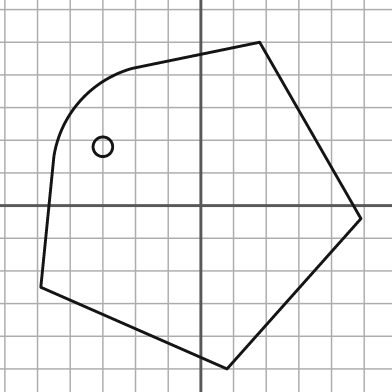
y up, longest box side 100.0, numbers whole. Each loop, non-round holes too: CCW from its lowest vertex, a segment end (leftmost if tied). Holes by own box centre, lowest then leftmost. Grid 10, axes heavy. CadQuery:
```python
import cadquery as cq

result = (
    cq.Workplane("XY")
    .moveTo(8.0, -50.0)
    .lineTo(49.0, -4.0)
    .lineTo(18.0, 50.0)
    .lineTo(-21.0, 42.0)
    .threePointArc((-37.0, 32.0), (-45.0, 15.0))
    .lineTo(-49.0, -25.0)
    .close()
    .moveTo(-30.0, 18.0)
    .circle(3.0)
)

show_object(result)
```